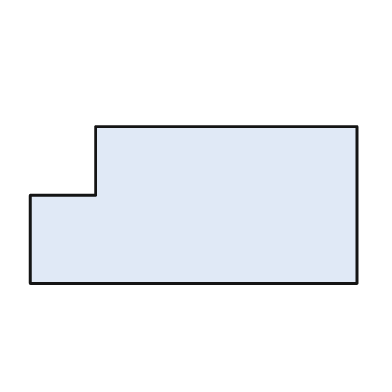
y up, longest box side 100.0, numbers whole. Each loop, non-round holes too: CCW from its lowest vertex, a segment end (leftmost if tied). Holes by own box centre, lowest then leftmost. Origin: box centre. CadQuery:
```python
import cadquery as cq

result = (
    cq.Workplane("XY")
    .moveTo(-50.0, -24.0)
    .lineTo(50.0, -24.0)
    .lineTo(50.0, 24.0)
    .lineTo(-30.0, 24.0)
    .lineTo(-30.0, 3.0)
    .lineTo(-50.0, 3.0)
    .close()
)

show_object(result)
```